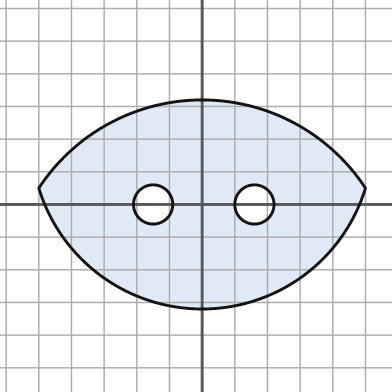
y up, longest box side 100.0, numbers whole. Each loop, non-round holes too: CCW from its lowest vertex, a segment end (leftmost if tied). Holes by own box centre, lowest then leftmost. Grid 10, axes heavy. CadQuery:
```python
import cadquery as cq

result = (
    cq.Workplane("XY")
    .moveTo(-50.0, 5.0)
    .threePointArc((0.0, -32.0), (50.0, 5.0))
    .threePointArc((0.0, 32.0), (-50.0, 5.0))
    .close()
    .moveTo(-15.0, 0.0)
    .circle(6.0)
    .moveTo(16.0, 0.0)
    .circle(6.0)
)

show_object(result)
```